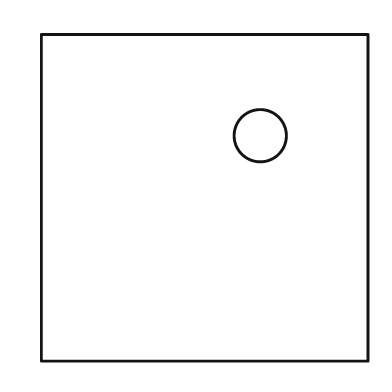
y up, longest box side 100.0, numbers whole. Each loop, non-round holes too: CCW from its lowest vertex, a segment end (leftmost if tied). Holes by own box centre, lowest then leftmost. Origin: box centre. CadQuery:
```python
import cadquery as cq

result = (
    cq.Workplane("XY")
    .moveTo(-50.0, -50.0)
    .lineTo(50.0, -50.0)
    .lineTo(50.0, 50.0)
    .lineTo(-50.0, 50.0)
    .close()
    .moveTo(17.0, 19.0)
    .circle(8.0)
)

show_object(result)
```